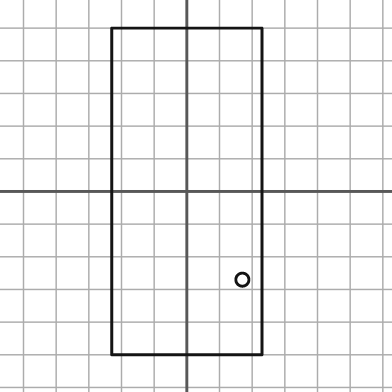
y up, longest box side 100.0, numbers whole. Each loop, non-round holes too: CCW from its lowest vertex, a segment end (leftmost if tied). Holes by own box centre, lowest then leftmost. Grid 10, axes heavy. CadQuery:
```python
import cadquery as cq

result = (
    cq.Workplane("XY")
    .moveTo(-23.0, -50.0)
    .lineTo(23.0, -50.0)
    .lineTo(23.0, 50.0)
    .lineTo(-23.0, 50.0)
    .close()
    .moveTo(17.0, -27.0)
    .circle(2.0)
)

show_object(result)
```